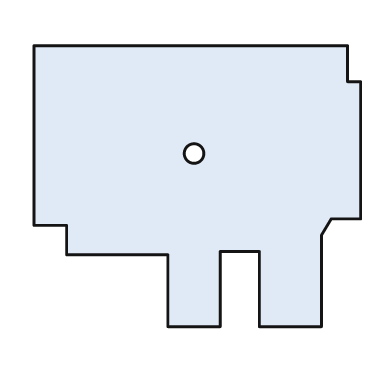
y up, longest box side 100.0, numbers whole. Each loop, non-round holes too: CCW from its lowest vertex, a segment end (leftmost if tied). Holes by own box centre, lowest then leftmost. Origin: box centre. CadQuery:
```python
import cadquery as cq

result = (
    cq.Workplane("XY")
    .moveTo(-9.0, -43.0)
    .lineTo(7.0, -43.0)
    .lineTo(7.0, -20.0)
    .lineTo(19.0, -20.0)
    .lineTo(19.0, -43.0)
    .lineTo(38.0, -43.0)
    .lineTo(38.0, -15.0)
    .lineTo(41.0, -10.0)
    .lineTo(50.0, -10.0)
    .lineTo(50.0, 32.0)
    .lineTo(46.0, 32.0)
    .lineTo(46.0, 43.0)
    .lineTo(-50.0, 43.0)
    .lineTo(-50.0, -12.0)
    .lineTo(-40.0, -12.0)
    .lineTo(-40.0, -21.0)
    .lineTo(-9.0, -21.0)
    .close()
    .moveTo(-1.0, 10.0)
    .circle(3.0)
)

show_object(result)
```